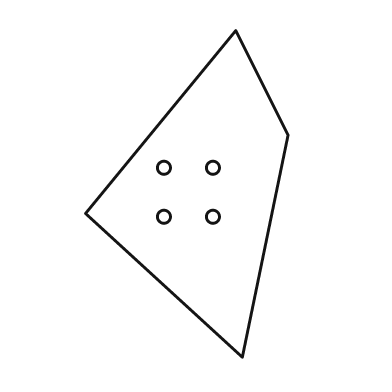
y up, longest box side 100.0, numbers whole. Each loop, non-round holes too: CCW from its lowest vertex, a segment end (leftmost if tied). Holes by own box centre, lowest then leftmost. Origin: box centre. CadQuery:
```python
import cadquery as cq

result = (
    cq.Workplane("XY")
    .moveTo(17.0, -50.0)
    .lineTo(31.0, 18.0)
    .lineTo(15.0, 50.0)
    .lineTo(-31.0, -6.0)
    .close()
    .moveTo(-7.0, -7.0)
    .circle(2.0)
    .moveTo(8.0, -7.0)
    .circle(2.0)
    .moveTo(-7.0, 8.0)
    .circle(2.0)
    .moveTo(8.0, 8.0)
    .circle(2.0)
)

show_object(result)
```